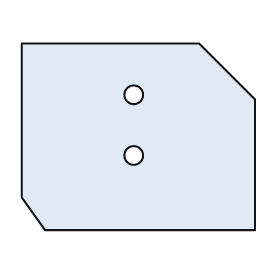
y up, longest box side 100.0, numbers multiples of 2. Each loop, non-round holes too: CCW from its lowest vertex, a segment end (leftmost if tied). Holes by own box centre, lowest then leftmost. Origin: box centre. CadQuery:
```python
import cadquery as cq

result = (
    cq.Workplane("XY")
    .moveTo(-40.0, -40.0)
    .lineTo(50.0, -40.0)
    .lineTo(50.0, 16.0)
    .lineTo(26.0, 40.0)
    .lineTo(-50.0, 40.0)
    .lineTo(-50.0, -26.0)
    .close()
    .moveTo(-2.0, -8.0)
    .circle(4.0)
    .moveTo(-2.0, 18.0)
    .circle(4.0)
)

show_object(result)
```